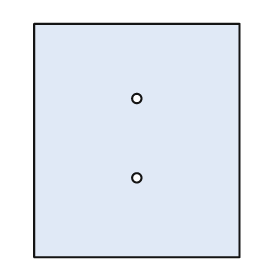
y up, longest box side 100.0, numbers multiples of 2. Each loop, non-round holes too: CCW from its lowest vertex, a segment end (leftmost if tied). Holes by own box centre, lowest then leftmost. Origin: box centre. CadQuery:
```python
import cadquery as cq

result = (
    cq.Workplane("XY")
    .moveTo(-44.0, -50.0)
    .lineTo(44.0, -50.0)
    .lineTo(44.0, 50.0)
    .lineTo(-44.0, 50.0)
    .close()
    .moveTo(0.0, -16.0)
    .circle(2.0)
    .moveTo(0.0, 18.0)
    .circle(2.0)
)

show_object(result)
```